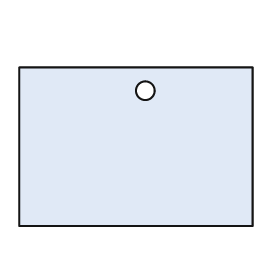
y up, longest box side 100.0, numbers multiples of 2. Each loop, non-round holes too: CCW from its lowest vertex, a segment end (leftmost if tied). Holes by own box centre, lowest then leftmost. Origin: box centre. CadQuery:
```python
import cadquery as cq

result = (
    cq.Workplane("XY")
    .moveTo(-50.0, -34.0)
    .lineTo(50.0, -34.0)
    .lineTo(50.0, 34.0)
    .lineTo(-50.0, 34.0)
    .close()
    .moveTo(4.0, 24.0)
    .circle(4.0)
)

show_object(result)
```